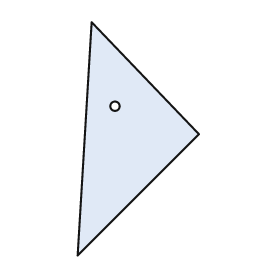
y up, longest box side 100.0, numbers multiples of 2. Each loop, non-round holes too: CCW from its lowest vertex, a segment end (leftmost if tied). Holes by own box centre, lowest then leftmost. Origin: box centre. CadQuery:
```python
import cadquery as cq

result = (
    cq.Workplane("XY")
    .moveTo(-26.0, -50.0)
    .lineTo(26.0, 2.0)
    .lineTo(-20.0, 50.0)
    .close()
    .moveTo(-10.0, 14.0)
    .circle(2.0)
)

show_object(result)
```